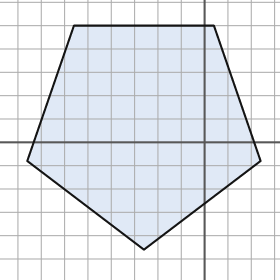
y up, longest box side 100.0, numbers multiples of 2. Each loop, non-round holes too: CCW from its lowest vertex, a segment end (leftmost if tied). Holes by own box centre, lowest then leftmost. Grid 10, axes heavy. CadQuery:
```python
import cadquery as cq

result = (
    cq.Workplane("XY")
    .moveTo(-26.0, -46.0)
    .lineTo(24.0, -8.0)
    .lineTo(4.0, 50.0)
    .lineTo(-56.0, 50.0)
    .lineTo(-76.0, -8.0)
    .close()
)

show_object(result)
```